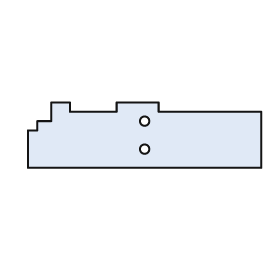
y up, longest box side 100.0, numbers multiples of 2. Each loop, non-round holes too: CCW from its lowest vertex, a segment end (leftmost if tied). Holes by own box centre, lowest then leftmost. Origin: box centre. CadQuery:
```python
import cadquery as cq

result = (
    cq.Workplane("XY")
    .moveTo(-50.0, -14.0)
    .lineTo(50.0, -14.0)
    .lineTo(50.0, 10.0)
    .lineTo(6.0, 10.0)
    .lineTo(6.0, 14.0)
    .lineTo(-12.0, 14.0)
    .lineTo(-12.0, 10.0)
    .lineTo(-32.0, 10.0)
    .lineTo(-32.0, 14.0)
    .lineTo(-40.0, 14.0)
    .lineTo(-40.0, 6.0)
    .lineTo(-46.0, 6.0)
    .lineTo(-46.0, 2.0)
    .lineTo(-50.0, 2.0)
    .close()
    .moveTo(0.0, -6.0)
    .circle(2.0)
    .moveTo(0.0, 6.0)
    .circle(2.0)
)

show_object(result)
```